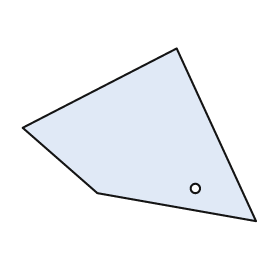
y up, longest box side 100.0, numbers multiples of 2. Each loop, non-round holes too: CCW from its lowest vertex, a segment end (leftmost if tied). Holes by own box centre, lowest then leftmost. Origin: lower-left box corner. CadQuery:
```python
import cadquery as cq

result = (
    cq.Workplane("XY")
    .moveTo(100.0, 0.0)
    .lineTo(66.0, 74.0)
    .lineTo(0.0, 40.0)
    .lineTo(32.0, 12.0)
    .close()
    .moveTo(74.0, 14.0)
    .circle(2.0)
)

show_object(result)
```